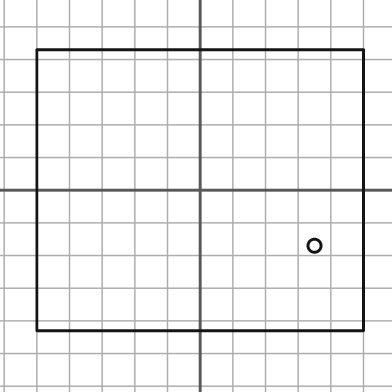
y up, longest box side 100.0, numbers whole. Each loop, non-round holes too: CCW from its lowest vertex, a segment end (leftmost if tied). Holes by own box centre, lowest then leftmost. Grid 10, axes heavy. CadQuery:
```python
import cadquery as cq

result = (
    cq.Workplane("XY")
    .moveTo(-50.0, -43.0)
    .lineTo(50.0, -43.0)
    .lineTo(50.0, 43.0)
    .lineTo(-50.0, 43.0)
    .close()
    .moveTo(35.0, -17.0)
    .circle(2.0)
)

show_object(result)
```